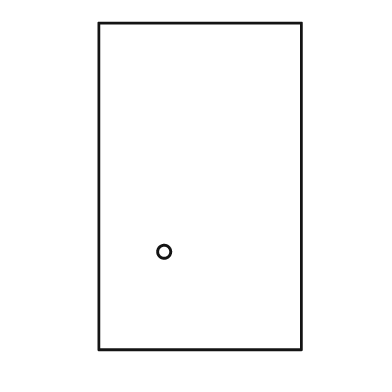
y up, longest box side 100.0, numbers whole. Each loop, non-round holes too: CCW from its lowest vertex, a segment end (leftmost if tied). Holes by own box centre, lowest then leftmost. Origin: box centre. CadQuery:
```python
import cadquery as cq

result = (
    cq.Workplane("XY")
    .moveTo(-31.0, -50.0)
    .lineTo(31.0, -50.0)
    .lineTo(31.0, 50.0)
    .lineTo(-31.0, 50.0)
    .close()
    .moveTo(-11.0, -20.0)
    .circle(2.0)
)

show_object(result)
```